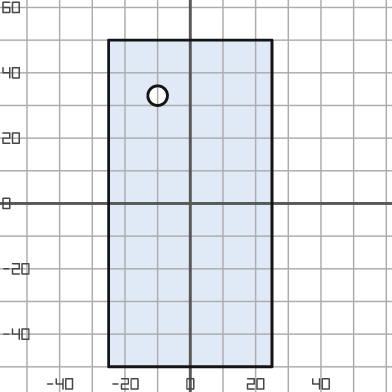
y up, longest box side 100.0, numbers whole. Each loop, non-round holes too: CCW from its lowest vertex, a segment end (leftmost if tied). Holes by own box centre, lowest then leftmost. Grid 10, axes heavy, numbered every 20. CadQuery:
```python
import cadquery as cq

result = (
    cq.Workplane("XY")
    .moveTo(-25.0, -50.0)
    .lineTo(25.0, -50.0)
    .lineTo(25.0, 50.0)
    .lineTo(-25.0, 50.0)
    .close()
    .moveTo(-10.0, 33.0)
    .circle(3.0)
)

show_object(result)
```